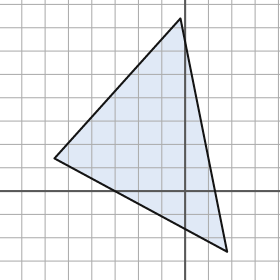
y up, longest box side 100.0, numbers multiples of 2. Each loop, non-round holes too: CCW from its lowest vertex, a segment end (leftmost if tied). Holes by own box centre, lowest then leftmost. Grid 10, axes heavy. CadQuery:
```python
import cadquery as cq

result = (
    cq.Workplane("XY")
    .moveTo(18.0, -26.0)
    .lineTo(-2.0, 74.0)
    .lineTo(-56.0, 14.0)
    .close()
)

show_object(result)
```